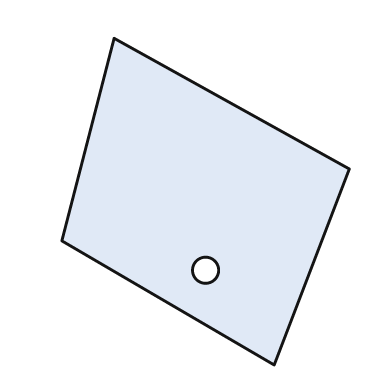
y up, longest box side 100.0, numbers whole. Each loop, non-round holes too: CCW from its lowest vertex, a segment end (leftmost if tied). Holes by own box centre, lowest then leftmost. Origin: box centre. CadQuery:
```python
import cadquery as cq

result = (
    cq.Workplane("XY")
    .moveTo(21.0, -50.0)
    .lineTo(44.0, 10.0)
    .lineTo(-28.0, 50.0)
    .lineTo(-44.0, -12.0)
    .close()
    .moveTo(0.0, -21.0)
    .circle(4.0)
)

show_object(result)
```